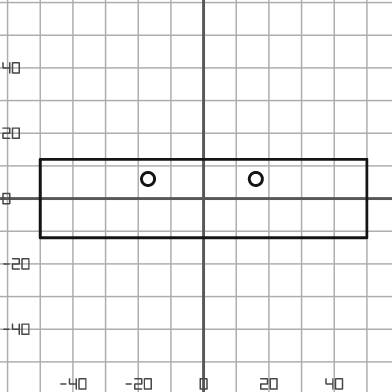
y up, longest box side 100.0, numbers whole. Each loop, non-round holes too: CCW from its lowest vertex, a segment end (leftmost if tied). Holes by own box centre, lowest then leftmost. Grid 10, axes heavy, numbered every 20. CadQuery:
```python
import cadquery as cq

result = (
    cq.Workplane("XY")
    .moveTo(-50.0, -12.0)
    .lineTo(50.0, -12.0)
    .lineTo(50.0, 12.0)
    .lineTo(-50.0, 12.0)
    .close()
    .moveTo(-17.0, 6.0)
    .circle(2.0)
    .moveTo(16.0, 6.0)
    .circle(2.0)
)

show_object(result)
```